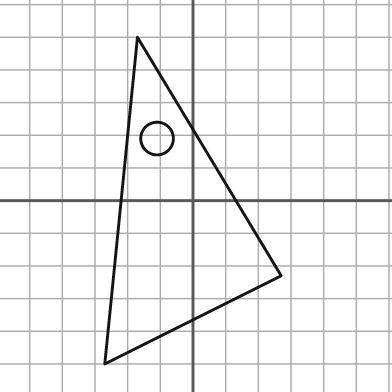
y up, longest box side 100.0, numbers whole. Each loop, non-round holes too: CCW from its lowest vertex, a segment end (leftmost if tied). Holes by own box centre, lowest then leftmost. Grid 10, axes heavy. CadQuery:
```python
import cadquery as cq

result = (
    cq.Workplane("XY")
    .moveTo(-27.0, -50.0)
    .lineTo(27.0, -23.0)
    .lineTo(-17.0, 50.0)
    .close()
    .moveTo(-11.0, 19.0)
    .circle(5.0)
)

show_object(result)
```